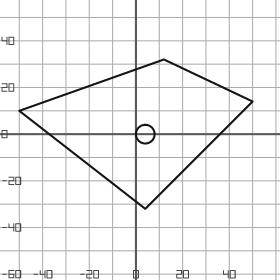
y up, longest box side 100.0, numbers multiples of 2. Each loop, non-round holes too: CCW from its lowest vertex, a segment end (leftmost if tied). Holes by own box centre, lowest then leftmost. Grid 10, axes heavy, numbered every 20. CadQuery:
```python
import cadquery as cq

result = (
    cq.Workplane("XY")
    .moveTo(4.0, -32.0)
    .lineTo(50.0, 14.0)
    .lineTo(12.0, 32.0)
    .lineTo(-50.0, 10.0)
    .close()
    .moveTo(4.0, 0.0)
    .circle(4.0)
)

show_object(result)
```